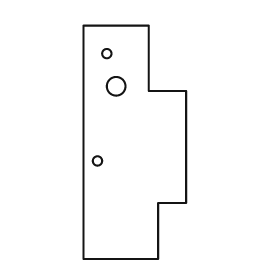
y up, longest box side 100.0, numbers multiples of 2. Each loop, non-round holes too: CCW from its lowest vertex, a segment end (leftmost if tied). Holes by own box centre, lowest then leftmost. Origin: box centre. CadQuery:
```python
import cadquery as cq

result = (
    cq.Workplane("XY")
    .moveTo(-22.0, -50.0)
    .lineTo(10.0, -50.0)
    .lineTo(10.0, -26.0)
    .lineTo(22.0, -26.0)
    .lineTo(22.0, 22.0)
    .lineTo(6.0, 22.0)
    .lineTo(6.0, 50.0)
    .lineTo(-22.0, 50.0)
    .close()
    .moveTo(-16.0, -8.0)
    .circle(2.0)
    .moveTo(-8.0, 24.0)
    .circle(4.0)
    .moveTo(-12.0, 38.0)
    .circle(2.0)
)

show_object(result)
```